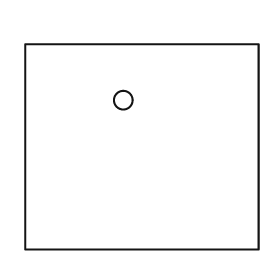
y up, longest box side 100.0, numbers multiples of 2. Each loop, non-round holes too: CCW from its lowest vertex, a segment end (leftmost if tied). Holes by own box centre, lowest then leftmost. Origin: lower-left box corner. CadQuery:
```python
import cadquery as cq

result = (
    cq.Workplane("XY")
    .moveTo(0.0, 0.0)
    .lineTo(100.0, 0.0)
    .lineTo(100.0, 88.0)
    .lineTo(0.0, 88.0)
    .close()
    .moveTo(42.0, 64.0)
    .circle(4.0)
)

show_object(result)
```